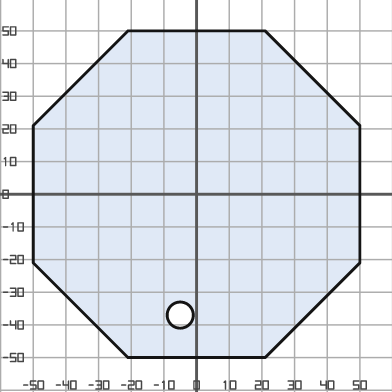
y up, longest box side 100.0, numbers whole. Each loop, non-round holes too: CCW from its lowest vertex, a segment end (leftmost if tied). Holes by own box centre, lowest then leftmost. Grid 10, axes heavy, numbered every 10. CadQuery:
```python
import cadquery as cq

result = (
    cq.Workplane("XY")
    .moveTo(-21.0, -50.0)
    .lineTo(21.0, -50.0)
    .lineTo(50.0, -21.0)
    .lineTo(50.0, 21.0)
    .lineTo(21.0, 50.0)
    .lineTo(-21.0, 50.0)
    .lineTo(-50.0, 21.0)
    .lineTo(-50.0, -21.0)
    .close()
    .moveTo(-5.0, -37.0)
    .circle(4.0)
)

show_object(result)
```